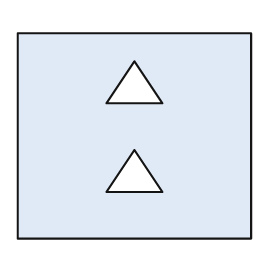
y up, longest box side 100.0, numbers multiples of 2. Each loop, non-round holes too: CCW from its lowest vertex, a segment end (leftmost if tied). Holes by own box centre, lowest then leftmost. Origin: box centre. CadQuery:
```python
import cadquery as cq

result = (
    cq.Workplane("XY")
    .moveTo(-50.0, -44.0)
    .lineTo(50.0, -44.0)
    .lineTo(50.0, 44.0)
    .lineTo(-50.0, 44.0)
    .close()
    .moveTo(-12.0, -24.0)
    .lineTo(12.0, -24.0)
    .lineTo(0.0, -6.0)
    .close()
    .moveTo(-12.0, 14.0)
    .lineTo(12.0, 14.0)
    .lineTo(0.0, 32.0)
    .close()
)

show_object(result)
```